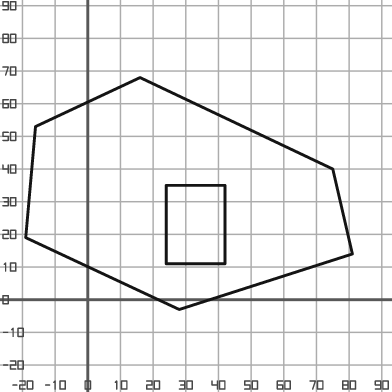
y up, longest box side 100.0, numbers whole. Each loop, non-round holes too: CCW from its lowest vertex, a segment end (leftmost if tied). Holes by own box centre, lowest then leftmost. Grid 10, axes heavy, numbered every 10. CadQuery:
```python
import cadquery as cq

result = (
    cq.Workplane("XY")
    .moveTo(28.0, -3.0)
    .lineTo(81.0, 14.0)
    .lineTo(75.0, 40.0)
    .lineTo(16.0, 68.0)
    .lineTo(-16.0, 53.0)
    .lineTo(-19.0, 19.0)
    .close()
    .moveTo(24.0, 11.0)
    .lineTo(42.0, 11.0)
    .lineTo(42.0, 35.0)
    .lineTo(24.0, 35.0)
    .close()
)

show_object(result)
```